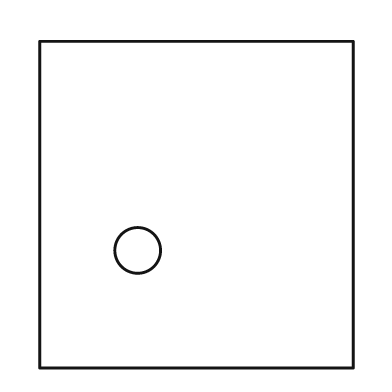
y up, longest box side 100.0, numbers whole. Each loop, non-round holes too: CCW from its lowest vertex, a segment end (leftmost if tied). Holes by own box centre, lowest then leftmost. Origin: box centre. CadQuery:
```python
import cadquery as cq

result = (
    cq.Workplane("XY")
    .moveTo(-48.0, -50.0)
    .lineTo(48.0, -50.0)
    .lineTo(48.0, 50.0)
    .lineTo(-48.0, 50.0)
    .close()
    .moveTo(-18.0, -14.0)
    .circle(7.0)
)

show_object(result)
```